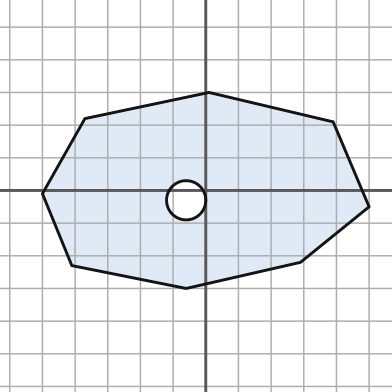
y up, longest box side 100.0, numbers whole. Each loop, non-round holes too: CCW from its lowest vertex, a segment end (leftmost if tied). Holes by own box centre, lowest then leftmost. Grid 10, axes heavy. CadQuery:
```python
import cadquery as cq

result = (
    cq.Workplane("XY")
    .moveTo(-6.0, -30.0)
    .lineTo(29.0, -22.0)
    .lineTo(50.0, -5.0)
    .lineTo(39.0, 21.0)
    .lineTo(1.0, 30.0)
    .lineTo(-37.0, 22.0)
    .lineTo(-50.0, -1.0)
    .lineTo(-41.0, -23.0)
    .close()
    .moveTo(-6.0, -3.0)
    .circle(6.0)
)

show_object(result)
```